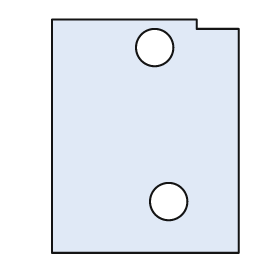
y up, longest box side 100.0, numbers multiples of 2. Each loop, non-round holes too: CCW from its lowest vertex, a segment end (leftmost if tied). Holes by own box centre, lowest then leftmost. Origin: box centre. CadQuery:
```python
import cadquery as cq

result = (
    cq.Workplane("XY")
    .moveTo(-40.0, -50.0)
    .lineTo(40.0, -50.0)
    .lineTo(40.0, 46.0)
    .lineTo(22.0, 46.0)
    .lineTo(22.0, 50.0)
    .lineTo(-40.0, 50.0)
    .close()
    .moveTo(10.0, -28.0)
    .circle(8.0)
    .moveTo(4.0, 38.0)
    .circle(8.0)
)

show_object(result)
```